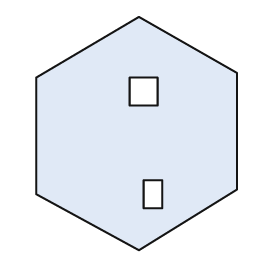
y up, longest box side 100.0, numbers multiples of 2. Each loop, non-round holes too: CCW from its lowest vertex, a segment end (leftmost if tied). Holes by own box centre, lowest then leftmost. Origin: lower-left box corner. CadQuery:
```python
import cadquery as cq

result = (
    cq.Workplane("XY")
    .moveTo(44.0, 0.0)
    .lineTo(86.0, 26.0)
    .lineTo(86.0, 76.0)
    .lineTo(44.0, 100.0)
    .lineTo(0.0, 74.0)
    .lineTo(0.0, 24.0)
    .close()
    .moveTo(46.0, 18.0)
    .lineTo(54.0, 18.0)
    .lineTo(54.0, 30.0)
    .lineTo(46.0, 30.0)
    .close()
    .moveTo(40.0, 62.0)
    .lineTo(52.0, 62.0)
    .lineTo(52.0, 74.0)
    .lineTo(40.0, 74.0)
    .close()
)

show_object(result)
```